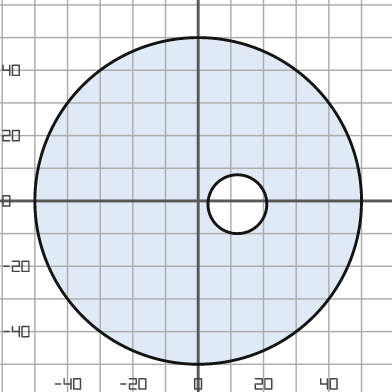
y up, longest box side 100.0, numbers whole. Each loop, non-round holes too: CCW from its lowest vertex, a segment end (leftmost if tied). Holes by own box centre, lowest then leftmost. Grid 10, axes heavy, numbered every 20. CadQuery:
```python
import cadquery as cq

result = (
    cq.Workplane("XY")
    .moveTo(0.0, 0.0)
    .circle(50.0)
    .moveTo(12.0, -1.0)
    .circle(9.0)
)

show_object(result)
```